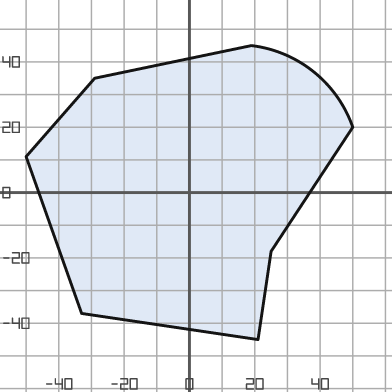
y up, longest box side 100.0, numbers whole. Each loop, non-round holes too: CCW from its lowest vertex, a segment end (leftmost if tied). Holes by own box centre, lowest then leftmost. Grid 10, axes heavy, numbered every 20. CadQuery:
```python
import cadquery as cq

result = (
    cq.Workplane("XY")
    .moveTo(21.0, -45.0)
    .lineTo(25.0, -18.0)
    .lineTo(50.0, 20.0)
    .threePointArc((38.0, 37.0), (19.0, 45.0))
    .lineTo(-29.0, 35.0)
    .lineTo(-50.0, 11.0)
    .lineTo(-33.0, -37.0)
    .close()
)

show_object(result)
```